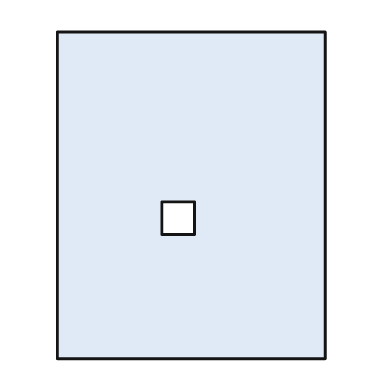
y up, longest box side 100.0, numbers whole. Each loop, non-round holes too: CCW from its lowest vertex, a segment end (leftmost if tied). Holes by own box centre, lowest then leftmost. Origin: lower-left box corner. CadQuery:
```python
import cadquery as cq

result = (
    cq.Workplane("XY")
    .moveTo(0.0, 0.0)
    .lineTo(82.0, 0.0)
    .lineTo(82.0, 100.0)
    .lineTo(0.0, 100.0)
    .close()
    .moveTo(32.0, 38.0)
    .lineTo(42.0, 38.0)
    .lineTo(42.0, 48.0)
    .lineTo(32.0, 48.0)
    .close()
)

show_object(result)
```